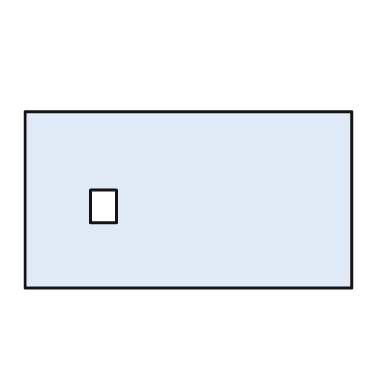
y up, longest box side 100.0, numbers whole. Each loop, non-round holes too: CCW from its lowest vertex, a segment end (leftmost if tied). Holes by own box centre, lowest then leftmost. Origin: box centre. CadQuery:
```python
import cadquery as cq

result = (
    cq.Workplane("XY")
    .moveTo(-50.0, -27.0)
    .lineTo(50.0, -27.0)
    .lineTo(50.0, 27.0)
    .lineTo(-50.0, 27.0)
    .close()
    .moveTo(-30.0, -7.0)
    .lineTo(-22.0, -7.0)
    .lineTo(-22.0, 3.0)
    .lineTo(-30.0, 3.0)
    .close()
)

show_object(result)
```